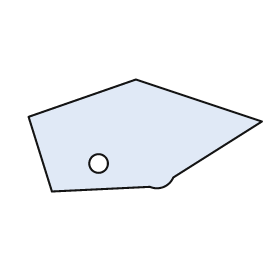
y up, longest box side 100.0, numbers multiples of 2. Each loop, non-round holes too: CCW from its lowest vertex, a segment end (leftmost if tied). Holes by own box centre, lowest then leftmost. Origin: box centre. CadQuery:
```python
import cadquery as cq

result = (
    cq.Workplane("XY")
    .moveTo(-40.0, -24.0)
    .lineTo(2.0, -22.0)
    .threePointArc((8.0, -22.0), (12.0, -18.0))
    .lineTo(50.0, 6.0)
    .lineTo(-4.0, 24.0)
    .lineTo(-50.0, 8.0)
    .close()
    .moveTo(-20.0, -12.0)
    .circle(4.0)
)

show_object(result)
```